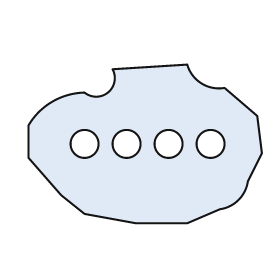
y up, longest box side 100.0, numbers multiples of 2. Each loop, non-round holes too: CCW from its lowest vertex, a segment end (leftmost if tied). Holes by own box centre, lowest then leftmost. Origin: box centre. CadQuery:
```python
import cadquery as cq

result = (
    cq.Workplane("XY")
    .moveTo(-4.0, -34.0)
    .lineTo(18.0, -34.0)
    .lineTo(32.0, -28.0)
    .threePointArc((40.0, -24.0), (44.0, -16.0))
    .lineTo(50.0, -4.0)
    .lineTo(48.0, 12.0)
    .lineTo(34.0, 24.0)
    .threePointArc((24.0, 26.0), (18.0, 34.0))
    .lineTo(-14.0, 32.0)
    .threePointArc((-16.0, 22.0), (-26.0, 22.0))
    .threePointArc((-40.0, 18.0), (-50.0, 8.0))
    .lineTo(-50.0, -6.0)
    .lineTo(-36.0, -22.0)
    .lineTo(-26.0, -30.0)
    .close()
    .moveTo(-26.0, 0.0)
    .circle(6.0)
    .moveTo(-8.0, 0.0)
    .circle(6.0)
    .moveTo(10.0, 0.0)
    .circle(6.0)
    .moveTo(28.0, 0.0)
    .circle(6.0)
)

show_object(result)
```